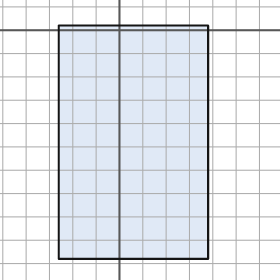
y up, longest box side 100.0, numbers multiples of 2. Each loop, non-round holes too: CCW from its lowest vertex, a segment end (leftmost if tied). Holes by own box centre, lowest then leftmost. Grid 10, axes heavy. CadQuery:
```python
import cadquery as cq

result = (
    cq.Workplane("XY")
    .moveTo(-26.0, -98.0)
    .lineTo(38.0, -98.0)
    .lineTo(38.0, 2.0)
    .lineTo(-26.0, 2.0)
    .close()
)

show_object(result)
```